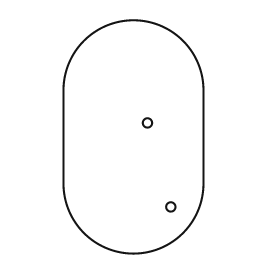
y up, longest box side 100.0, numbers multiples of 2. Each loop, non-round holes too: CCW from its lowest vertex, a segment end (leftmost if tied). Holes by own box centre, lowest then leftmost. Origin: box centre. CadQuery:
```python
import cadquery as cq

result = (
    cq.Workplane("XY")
    .moveTo(-30.0, -20.0)
    .threePointArc((0.0, -50.0), (30.0, -20.0))
    .lineTo(30.0, 20.0)
    .threePointArc((0.0, 50.0), (-30.0, 20.0))
    .close()
    .moveTo(16.0, -30.0)
    .circle(2.0)
    .moveTo(6.0, 6.0)
    .circle(2.0)
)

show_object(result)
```